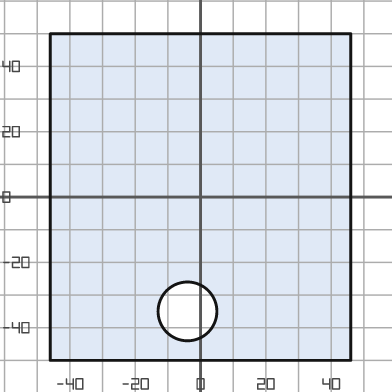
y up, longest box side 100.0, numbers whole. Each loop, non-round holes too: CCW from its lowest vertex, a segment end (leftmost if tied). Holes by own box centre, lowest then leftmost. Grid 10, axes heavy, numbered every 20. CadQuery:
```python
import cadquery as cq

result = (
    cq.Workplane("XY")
    .moveTo(-46.0, -50.0)
    .lineTo(46.0, -50.0)
    .lineTo(46.0, 50.0)
    .lineTo(-46.0, 50.0)
    .close()
    .moveTo(-4.0, -35.0)
    .circle(9.0)
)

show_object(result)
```